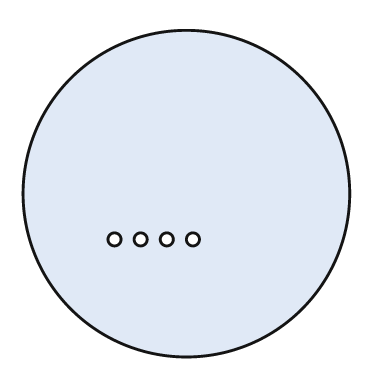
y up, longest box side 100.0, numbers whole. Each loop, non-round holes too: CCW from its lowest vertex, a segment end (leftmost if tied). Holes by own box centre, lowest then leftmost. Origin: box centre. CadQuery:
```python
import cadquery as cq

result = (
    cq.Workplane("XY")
    .moveTo(0.0, 0.0)
    .circle(50.0)
    .moveTo(-22.0, -14.0)
    .circle(2.0)
    .moveTo(-14.0, -14.0)
    .circle(2.0)
    .moveTo(-6.0, -14.0)
    .circle(2.0)
    .moveTo(2.0, -14.0)
    .circle(2.0)
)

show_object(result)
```